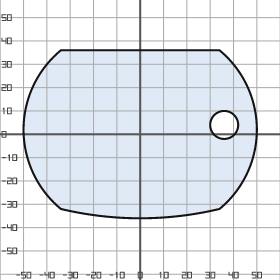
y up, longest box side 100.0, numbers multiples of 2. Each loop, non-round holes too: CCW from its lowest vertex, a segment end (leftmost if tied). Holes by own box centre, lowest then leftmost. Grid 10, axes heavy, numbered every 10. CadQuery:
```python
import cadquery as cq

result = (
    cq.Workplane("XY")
    .moveTo(-34.0, -32.0)
    .threePointArc((0.0, -36.0), (34.0, -32.0))
    .threePointArc((50.0, 2.0), (34.0, 36.0))
    .lineTo(-34.0, 36.0)
    .threePointArc((-50.0, 2.0), (-34.0, -32.0))
    .close()
    .moveTo(36.0, 4.0)
    .circle(6.0)
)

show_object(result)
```